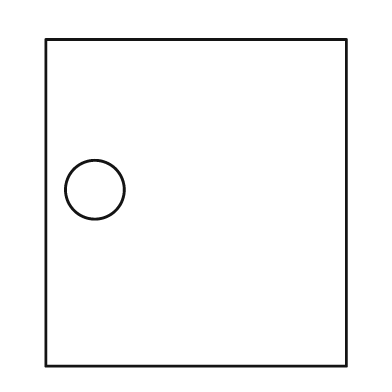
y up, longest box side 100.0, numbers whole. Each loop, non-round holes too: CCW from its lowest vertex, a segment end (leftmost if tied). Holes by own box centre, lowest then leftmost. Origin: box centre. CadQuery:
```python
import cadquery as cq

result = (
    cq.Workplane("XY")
    .moveTo(-46.0, -50.0)
    .lineTo(46.0, -50.0)
    .lineTo(46.0, 50.0)
    .lineTo(-46.0, 50.0)
    .close()
    .moveTo(-31.0, 4.0)
    .circle(9.0)
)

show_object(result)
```